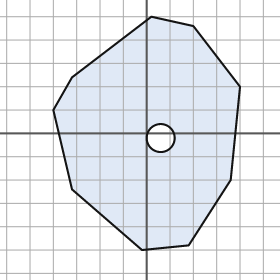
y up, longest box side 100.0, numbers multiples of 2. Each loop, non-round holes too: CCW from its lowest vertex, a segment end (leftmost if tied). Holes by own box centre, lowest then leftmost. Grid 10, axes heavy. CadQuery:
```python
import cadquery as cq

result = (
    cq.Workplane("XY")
    .moveTo(-2.0, -50.0)
    .lineTo(18.0, -48.0)
    .lineTo(36.0, -20.0)
    .lineTo(40.0, 20.0)
    .lineTo(20.0, 46.0)
    .lineTo(2.0, 50.0)
    .lineTo(-32.0, 24.0)
    .lineTo(-40.0, 10.0)
    .lineTo(-32.0, -24.0)
    .close()
    .moveTo(6.0, -2.0)
    .circle(6.0)
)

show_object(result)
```